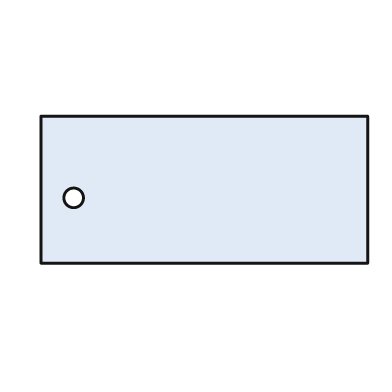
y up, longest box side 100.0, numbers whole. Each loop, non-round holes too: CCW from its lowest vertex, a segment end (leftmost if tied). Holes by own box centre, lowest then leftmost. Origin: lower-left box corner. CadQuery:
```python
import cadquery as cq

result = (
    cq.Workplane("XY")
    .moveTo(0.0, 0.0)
    .lineTo(100.0, 0.0)
    .lineTo(100.0, 45.0)
    .lineTo(0.0, 45.0)
    .close()
    .moveTo(10.0, 20.0)
    .circle(3.0)
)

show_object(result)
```